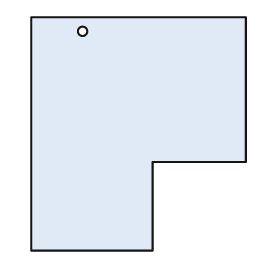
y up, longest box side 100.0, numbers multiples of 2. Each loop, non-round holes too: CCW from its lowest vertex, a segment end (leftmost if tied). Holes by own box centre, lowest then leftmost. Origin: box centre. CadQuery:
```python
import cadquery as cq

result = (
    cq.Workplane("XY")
    .moveTo(-46.0, -50.0)
    .lineTo(6.0, -50.0)
    .lineTo(6.0, -12.0)
    .lineTo(46.0, -12.0)
    .lineTo(46.0, 50.0)
    .lineTo(-46.0, 50.0)
    .close()
    .moveTo(-24.0, 44.0)
    .circle(2.0)
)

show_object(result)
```